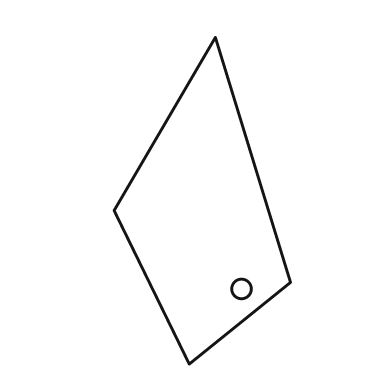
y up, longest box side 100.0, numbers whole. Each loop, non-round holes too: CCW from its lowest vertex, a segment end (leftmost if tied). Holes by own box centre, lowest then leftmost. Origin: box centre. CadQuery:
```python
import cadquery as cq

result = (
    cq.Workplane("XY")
    .moveTo(-4.0, -50.0)
    .lineTo(27.0, -25.0)
    .lineTo(4.0, 50.0)
    .lineTo(-27.0, -3.0)
    .close()
    .moveTo(12.0, -27.0)
    .circle(3.0)
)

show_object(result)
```